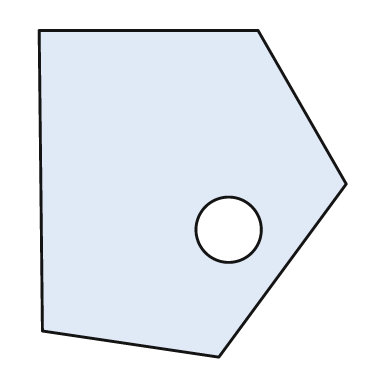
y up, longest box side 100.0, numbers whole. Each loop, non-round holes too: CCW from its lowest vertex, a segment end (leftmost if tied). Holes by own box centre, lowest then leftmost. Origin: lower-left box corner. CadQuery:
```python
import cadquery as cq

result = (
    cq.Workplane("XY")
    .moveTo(55.0, 0.0)
    .lineTo(94.0, 53.0)
    .lineTo(67.0, 100.0)
    .lineTo(0.0, 100.0)
    .lineTo(1.0, 8.0)
    .close()
    .moveTo(58.0, 39.0)
    .circle(10.0)
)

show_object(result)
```